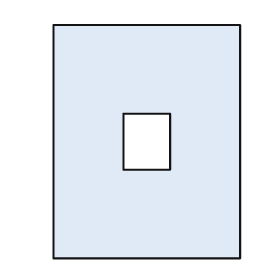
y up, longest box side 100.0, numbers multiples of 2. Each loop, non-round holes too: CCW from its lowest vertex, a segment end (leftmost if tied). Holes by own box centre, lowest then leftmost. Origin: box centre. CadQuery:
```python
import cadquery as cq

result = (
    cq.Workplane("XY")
    .moveTo(-40.0, -50.0)
    .lineTo(40.0, -50.0)
    .lineTo(40.0, 50.0)
    .lineTo(-40.0, 50.0)
    .close()
    .moveTo(-10.0, -12.0)
    .lineTo(10.0, -12.0)
    .lineTo(10.0, 12.0)
    .lineTo(-10.0, 12.0)
    .close()
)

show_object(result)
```